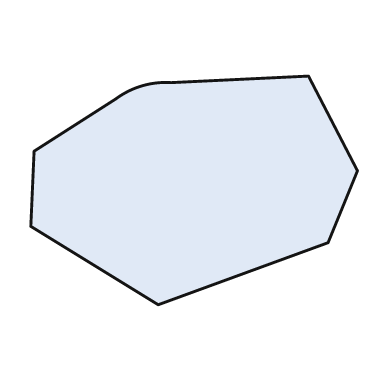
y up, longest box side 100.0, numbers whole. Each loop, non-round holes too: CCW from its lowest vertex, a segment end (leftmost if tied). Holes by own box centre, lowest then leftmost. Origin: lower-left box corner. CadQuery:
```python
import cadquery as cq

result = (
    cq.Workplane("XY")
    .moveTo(39.0, 0.0)
    .lineTo(91.0, 19.0)
    .lineTo(100.0, 41.0)
    .lineTo(85.0, 70.0)
    .lineTo(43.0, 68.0)
    .threePointArc((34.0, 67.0), (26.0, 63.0))
    .lineTo(1.0, 47.0)
    .lineTo(0.0, 24.0)
    .close()
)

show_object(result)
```